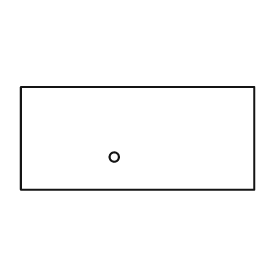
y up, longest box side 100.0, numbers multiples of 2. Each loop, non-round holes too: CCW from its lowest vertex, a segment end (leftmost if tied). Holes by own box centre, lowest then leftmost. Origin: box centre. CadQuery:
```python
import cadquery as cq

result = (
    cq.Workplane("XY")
    .moveTo(-50.0, -22.0)
    .lineTo(50.0, -22.0)
    .lineTo(50.0, 22.0)
    .lineTo(-50.0, 22.0)
    .close()
    .moveTo(-10.0, -8.0)
    .circle(2.0)
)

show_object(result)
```